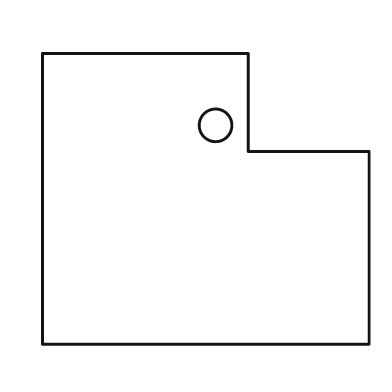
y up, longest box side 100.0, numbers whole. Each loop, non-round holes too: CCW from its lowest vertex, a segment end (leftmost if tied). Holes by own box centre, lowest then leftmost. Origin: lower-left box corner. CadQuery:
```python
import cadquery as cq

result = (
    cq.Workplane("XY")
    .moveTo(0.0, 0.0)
    .lineTo(100.0, 0.0)
    .lineTo(100.0, 59.0)
    .lineTo(63.0, 59.0)
    .lineTo(63.0, 89.0)
    .lineTo(0.0, 89.0)
    .close()
    .moveTo(53.0, 67.0)
    .circle(5.0)
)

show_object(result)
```